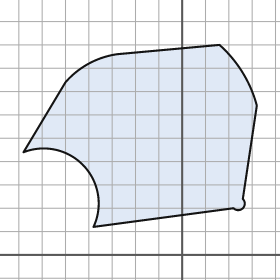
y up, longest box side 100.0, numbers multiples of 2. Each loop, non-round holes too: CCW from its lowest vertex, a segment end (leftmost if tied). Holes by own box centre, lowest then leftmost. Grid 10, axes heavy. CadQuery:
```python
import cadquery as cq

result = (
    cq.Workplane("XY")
    .moveTo(-38.0, 12.0)
    .lineTo(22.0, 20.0)
    .threePointArc((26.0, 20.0), (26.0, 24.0))
    .lineTo(32.0, 64.0)
    .threePointArc((26.0, 78.0), (16.0, 90.0))
    .lineTo(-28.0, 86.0)
    .threePointArc((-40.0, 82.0), (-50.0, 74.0))
    .lineTo(-68.0, 44.0)
    .threePointArc((-42.0, 38.0), (-38.0, 12.0))
    .close()
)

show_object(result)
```